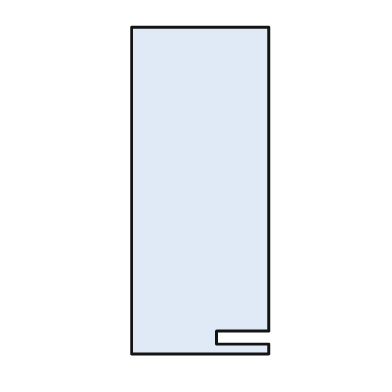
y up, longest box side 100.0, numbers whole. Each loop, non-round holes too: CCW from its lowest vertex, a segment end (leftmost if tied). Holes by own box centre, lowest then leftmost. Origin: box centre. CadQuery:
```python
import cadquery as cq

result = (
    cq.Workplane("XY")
    .moveTo(-21.0, -50.0)
    .lineTo(21.0, -50.0)
    .lineTo(21.0, -47.0)
    .lineTo(5.0, -47.0)
    .lineTo(5.0, -43.0)
    .lineTo(21.0, -43.0)
    .lineTo(21.0, 50.0)
    .lineTo(-21.0, 50.0)
    .close()
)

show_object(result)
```